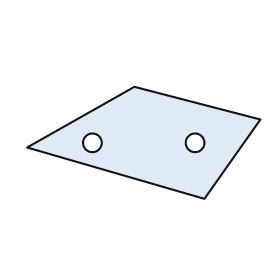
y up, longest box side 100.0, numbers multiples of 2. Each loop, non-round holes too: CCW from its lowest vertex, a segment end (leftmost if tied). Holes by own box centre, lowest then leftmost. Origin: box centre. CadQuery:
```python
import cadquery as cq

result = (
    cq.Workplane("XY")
    .moveTo(26.0, -24.0)
    .lineTo(50.0, 10.0)
    .lineTo(-4.0, 24.0)
    .lineTo(-50.0, -2.0)
    .close()
    .moveTo(-22.0, 0.0)
    .circle(4.0)
    .moveTo(22.0, 0.0)
    .circle(4.0)
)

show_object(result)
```